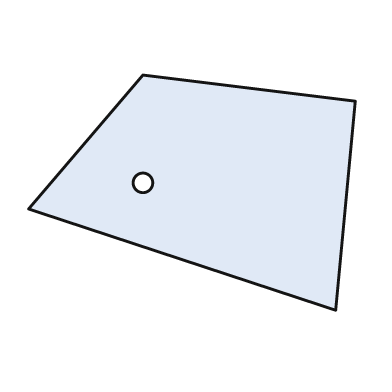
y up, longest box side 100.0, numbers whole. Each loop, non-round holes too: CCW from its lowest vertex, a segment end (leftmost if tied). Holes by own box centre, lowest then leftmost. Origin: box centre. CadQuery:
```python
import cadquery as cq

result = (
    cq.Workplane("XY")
    .moveTo(44.0, -36.0)
    .lineTo(50.0, 28.0)
    .lineTo(-15.0, 36.0)
    .lineTo(-50.0, -5.0)
    .close()
    .moveTo(-15.0, 3.0)
    .circle(3.0)
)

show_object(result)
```